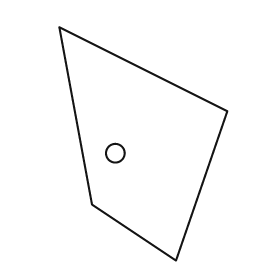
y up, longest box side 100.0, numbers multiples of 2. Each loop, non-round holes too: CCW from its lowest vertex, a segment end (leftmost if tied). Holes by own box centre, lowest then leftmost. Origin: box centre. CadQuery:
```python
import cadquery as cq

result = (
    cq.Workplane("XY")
    .moveTo(14.0, -50.0)
    .lineTo(36.0, 14.0)
    .lineTo(-36.0, 50.0)
    .lineTo(-22.0, -26.0)
    .close()
    .moveTo(-12.0, -4.0)
    .circle(4.0)
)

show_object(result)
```